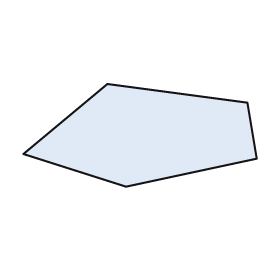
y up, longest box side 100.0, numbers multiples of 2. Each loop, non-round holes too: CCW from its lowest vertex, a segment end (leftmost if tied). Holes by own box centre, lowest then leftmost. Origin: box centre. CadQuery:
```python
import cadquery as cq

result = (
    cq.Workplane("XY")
    .moveTo(-6.0, -22.0)
    .lineTo(50.0, -10.0)
    .lineTo(46.0, 14.0)
    .lineTo(-14.0, 22.0)
    .lineTo(-50.0, -8.0)
    .close()
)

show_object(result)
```